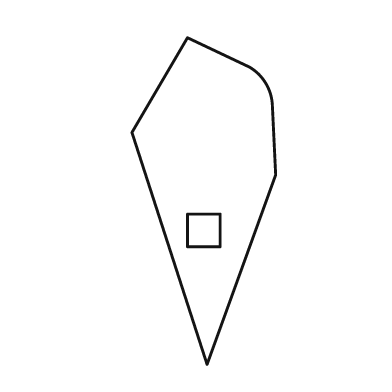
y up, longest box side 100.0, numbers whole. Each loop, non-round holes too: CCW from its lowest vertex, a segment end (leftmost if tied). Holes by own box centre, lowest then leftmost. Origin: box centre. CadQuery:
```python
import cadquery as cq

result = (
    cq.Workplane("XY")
    .moveTo(1.0, -50.0)
    .lineTo(22.0, 8.0)
    .lineTo(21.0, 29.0)
    .threePointArc((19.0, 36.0), (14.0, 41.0))
    .lineTo(-5.0, 50.0)
    .lineTo(-22.0, 21.0)
    .close()
    .moveTo(-5.0, -14.0)
    .lineTo(5.0, -14.0)
    .lineTo(5.0, -4.0)
    .lineTo(-5.0, -4.0)
    .close()
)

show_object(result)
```